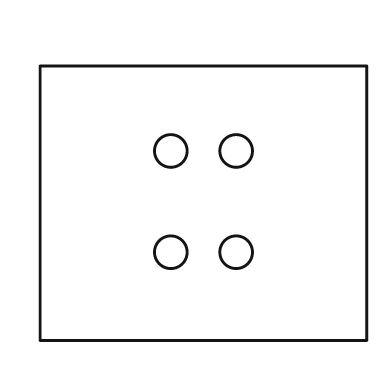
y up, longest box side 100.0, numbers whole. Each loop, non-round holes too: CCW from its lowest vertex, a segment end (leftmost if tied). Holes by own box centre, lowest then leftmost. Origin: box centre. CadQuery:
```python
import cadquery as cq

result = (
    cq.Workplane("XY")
    .moveTo(-50.0, -42.0)
    .lineTo(50.0, -42.0)
    .lineTo(50.0, 42.0)
    .lineTo(-50.0, 42.0)
    .close()
    .moveTo(-10.0, -15.0)
    .circle(5.0)
    .moveTo(10.0, -15.0)
    .circle(5.0)
    .moveTo(-10.0, 16.0)
    .circle(5.0)
    .moveTo(10.0, 16.0)
    .circle(5.0)
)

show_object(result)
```